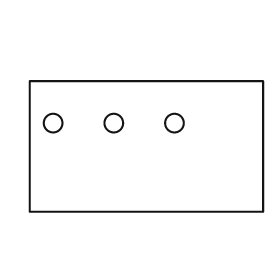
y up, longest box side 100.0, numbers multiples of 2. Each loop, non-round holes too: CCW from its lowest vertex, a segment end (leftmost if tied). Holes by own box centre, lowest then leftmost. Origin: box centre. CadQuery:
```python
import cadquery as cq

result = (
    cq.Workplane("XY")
    .moveTo(-50.0, -28.0)
    .lineTo(50.0, -28.0)
    .lineTo(50.0, 28.0)
    .lineTo(-50.0, 28.0)
    .close()
    .moveTo(-40.0, 10.0)
    .circle(4.0)
    .moveTo(-14.0, 10.0)
    .circle(4.0)
    .moveTo(12.0, 10.0)
    .circle(4.0)
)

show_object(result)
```